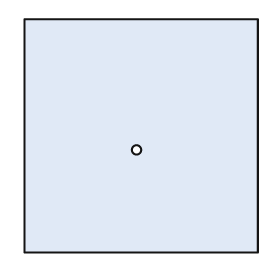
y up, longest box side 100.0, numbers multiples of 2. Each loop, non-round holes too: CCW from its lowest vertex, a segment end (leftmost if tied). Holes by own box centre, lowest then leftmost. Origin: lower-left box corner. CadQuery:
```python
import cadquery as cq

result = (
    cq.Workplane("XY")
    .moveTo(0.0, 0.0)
    .lineTo(100.0, 0.0)
    .lineTo(100.0, 100.0)
    .lineTo(0.0, 100.0)
    .close()
    .moveTo(48.0, 44.0)
    .circle(2.0)
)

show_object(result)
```